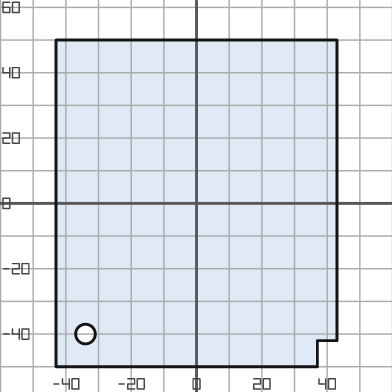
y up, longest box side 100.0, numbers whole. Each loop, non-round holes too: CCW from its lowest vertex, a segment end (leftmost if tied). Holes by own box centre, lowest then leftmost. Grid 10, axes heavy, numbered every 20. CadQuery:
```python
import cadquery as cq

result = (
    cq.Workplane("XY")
    .moveTo(-43.0, -50.0)
    .lineTo(37.0, -50.0)
    .lineTo(37.0, -42.0)
    .lineTo(43.0, -42.0)
    .lineTo(43.0, 50.0)
    .lineTo(-43.0, 50.0)
    .close()
    .moveTo(-34.0, -40.0)
    .circle(3.0)
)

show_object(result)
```